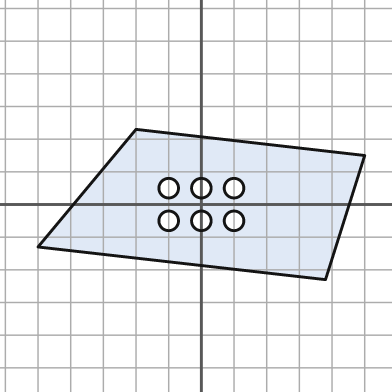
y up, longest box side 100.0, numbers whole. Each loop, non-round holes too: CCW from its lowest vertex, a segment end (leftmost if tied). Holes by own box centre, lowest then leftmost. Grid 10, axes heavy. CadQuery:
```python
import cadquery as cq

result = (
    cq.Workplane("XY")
    .moveTo(38.0, -23.0)
    .lineTo(50.0, 15.0)
    .lineTo(-20.0, 23.0)
    .lineTo(-50.0, -13.0)
    .close()
    .moveTo(-10.0, -5.0)
    .circle(3.0)
    .moveTo(0.0, -5.0)
    .circle(3.0)
    .moveTo(10.0, -5.0)
    .circle(3.0)
    .moveTo(-10.0, 5.0)
    .circle(3.0)
    .moveTo(0.0, 5.0)
    .circle(3.0)
    .moveTo(10.0, 5.0)
    .circle(3.0)
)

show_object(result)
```